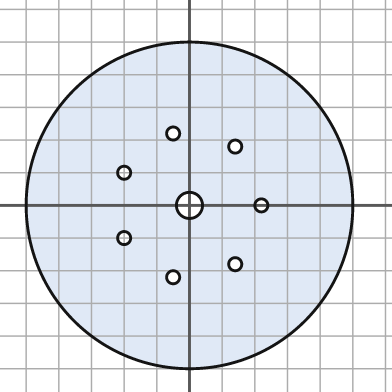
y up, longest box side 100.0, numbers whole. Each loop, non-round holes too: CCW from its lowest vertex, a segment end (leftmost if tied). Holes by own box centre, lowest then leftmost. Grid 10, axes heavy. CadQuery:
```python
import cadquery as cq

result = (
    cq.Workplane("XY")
    .moveTo(0.0, 0.0)
    .circle(50.0)
    .moveTo(-5.0, -22.0)
    .circle(2.0)
    .moveTo(14.0, -18.0)
    .circle(2.0)
    .moveTo(-20.0, -10.0)
    .circle(2.0)
    .moveTo(0.0, 0.0)
    .circle(4.0)
    .moveTo(22.0, 0.0)
    .circle(2.0)
    .moveTo(-20.0, 10.0)
    .circle(2.0)
    .moveTo(14.0, 18.0)
    .circle(2.0)
    .moveTo(-5.0, 22.0)
    .circle(2.0)
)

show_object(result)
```